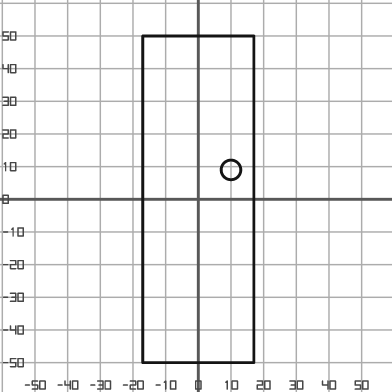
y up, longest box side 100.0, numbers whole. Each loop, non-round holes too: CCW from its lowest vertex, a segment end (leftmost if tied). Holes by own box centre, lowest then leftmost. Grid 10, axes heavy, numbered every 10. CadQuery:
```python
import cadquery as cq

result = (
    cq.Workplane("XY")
    .moveTo(-17.0, -50.0)
    .lineTo(17.0, -50.0)
    .lineTo(17.0, 50.0)
    .lineTo(-17.0, 50.0)
    .close()
    .moveTo(10.0, 9.0)
    .circle(3.0)
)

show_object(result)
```